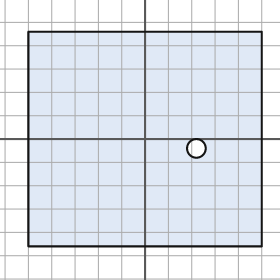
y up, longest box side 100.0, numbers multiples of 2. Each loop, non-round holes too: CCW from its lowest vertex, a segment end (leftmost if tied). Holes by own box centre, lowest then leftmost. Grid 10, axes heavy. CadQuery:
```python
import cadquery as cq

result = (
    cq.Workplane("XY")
    .moveTo(-50.0, -46.0)
    .lineTo(50.0, -46.0)
    .lineTo(50.0, 46.0)
    .lineTo(-50.0, 46.0)
    .close()
    .moveTo(22.0, -4.0)
    .circle(4.0)
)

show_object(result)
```